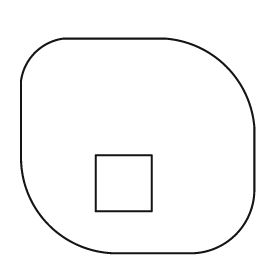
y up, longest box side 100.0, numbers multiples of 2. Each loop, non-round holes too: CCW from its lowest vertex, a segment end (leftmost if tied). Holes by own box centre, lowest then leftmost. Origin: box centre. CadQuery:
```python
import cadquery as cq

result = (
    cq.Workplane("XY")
    .moveTo(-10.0, -46.0)
    .lineTo(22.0, -46.0)
    .threePointArc((42.0, -38.0), (50.0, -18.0))
    .lineTo(50.0, 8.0)
    .threePointArc((38.0, 34.0), (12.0, 46.0))
    .lineTo(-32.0, 46.0)
    .threePointArc((-44.0, 40.0), (-50.0, 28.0))
    .lineTo(-50.0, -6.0)
    .threePointArc((-38.0, -34.0), (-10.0, -46.0))
    .close()
    .moveTo(-18.0, -28.0)
    .lineTo(6.0, -28.0)
    .lineTo(6.0, -4.0)
    .lineTo(-18.0, -4.0)
    .close()
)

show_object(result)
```